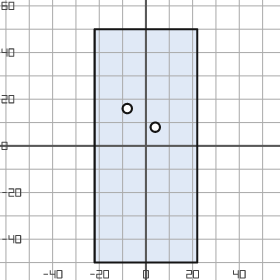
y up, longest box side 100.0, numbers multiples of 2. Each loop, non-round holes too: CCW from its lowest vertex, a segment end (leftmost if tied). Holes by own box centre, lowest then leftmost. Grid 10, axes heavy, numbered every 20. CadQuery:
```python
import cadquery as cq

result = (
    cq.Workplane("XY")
    .moveTo(-22.0, -50.0)
    .lineTo(22.0, -50.0)
    .lineTo(22.0, 50.0)
    .lineTo(-22.0, 50.0)
    .close()
    .moveTo(4.0, 8.0)
    .circle(2.0)
    .moveTo(-8.0, 16.0)
    .circle(2.0)
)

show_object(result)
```